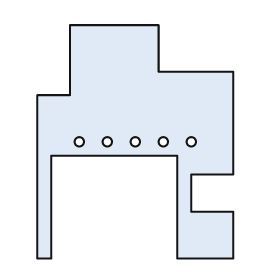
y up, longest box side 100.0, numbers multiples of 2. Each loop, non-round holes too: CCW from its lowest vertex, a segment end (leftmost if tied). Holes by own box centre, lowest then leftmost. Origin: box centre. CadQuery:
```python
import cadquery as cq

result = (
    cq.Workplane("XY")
    .moveTo(-42.0, -50.0)
    .lineTo(-36.0, -50.0)
    .lineTo(-36.0, -6.0)
    .lineTo(18.0, -6.0)
    .lineTo(18.0, -50.0)
    .lineTo(42.0, -50.0)
    .lineTo(42.0, -30.0)
    .lineTo(24.0, -30.0)
    .lineTo(24.0, -14.0)
    .lineTo(42.0, -14.0)
    .lineTo(42.0, 30.0)
    .lineTo(10.0, 30.0)
    .lineTo(10.0, 50.0)
    .lineTo(-28.0, 50.0)
    .lineTo(-28.0, 20.0)
    .lineTo(-42.0, 20.0)
    .close()
    .moveTo(-24.0, 0.0)
    .circle(2.0)
    .moveTo(-12.0, 0.0)
    .circle(2.0)
    .moveTo(0.0, 0.0)
    .circle(2.0)
    .moveTo(12.0, 0.0)
    .circle(2.0)
    .moveTo(24.0, 0.0)
    .circle(2.0)
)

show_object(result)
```